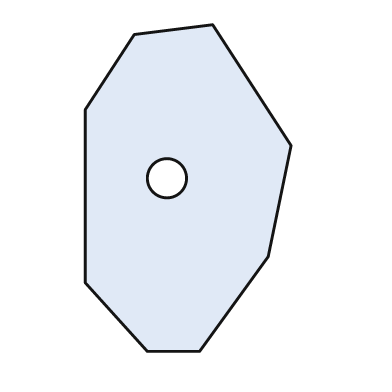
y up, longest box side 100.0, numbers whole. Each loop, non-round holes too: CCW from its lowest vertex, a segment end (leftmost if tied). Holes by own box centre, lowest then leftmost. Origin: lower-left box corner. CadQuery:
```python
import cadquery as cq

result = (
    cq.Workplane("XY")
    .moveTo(19.0, 0.0)
    .lineTo(35.0, 0.0)
    .lineTo(56.0, 29.0)
    .lineTo(63.0, 63.0)
    .lineTo(39.0, 100.0)
    .lineTo(15.0, 97.0)
    .lineTo(0.0, 74.0)
    .lineTo(0.0, 21.0)
    .close()
    .moveTo(25.0, 53.0)
    .circle(6.0)
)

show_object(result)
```